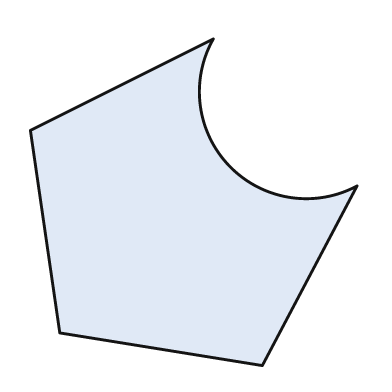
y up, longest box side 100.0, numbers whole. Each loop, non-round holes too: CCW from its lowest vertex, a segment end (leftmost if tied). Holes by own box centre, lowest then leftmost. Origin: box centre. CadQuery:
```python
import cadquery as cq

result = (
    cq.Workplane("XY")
    .moveTo(21.0, -50.0)
    .lineTo(50.0, 5.0)
    .threePointArc((11.0, 11.0), (6.0, 50.0))
    .lineTo(-50.0, 22.0)
    .lineTo(-41.0, -40.0)
    .close()
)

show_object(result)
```